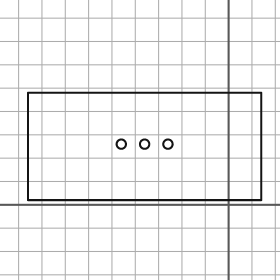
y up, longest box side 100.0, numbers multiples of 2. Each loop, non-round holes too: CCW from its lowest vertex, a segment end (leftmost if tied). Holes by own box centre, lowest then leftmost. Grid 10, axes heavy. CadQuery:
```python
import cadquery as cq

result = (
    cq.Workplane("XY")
    .moveTo(-86.0, 2.0)
    .lineTo(14.0, 2.0)
    .lineTo(14.0, 48.0)
    .lineTo(-86.0, 48.0)
    .close()
    .moveTo(-46.0, 26.0)
    .circle(2.0)
    .moveTo(-36.0, 26.0)
    .circle(2.0)
    .moveTo(-26.0, 26.0)
    .circle(2.0)
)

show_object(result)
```